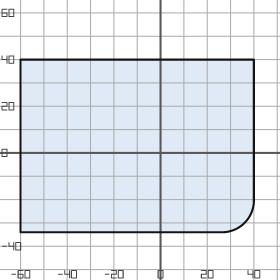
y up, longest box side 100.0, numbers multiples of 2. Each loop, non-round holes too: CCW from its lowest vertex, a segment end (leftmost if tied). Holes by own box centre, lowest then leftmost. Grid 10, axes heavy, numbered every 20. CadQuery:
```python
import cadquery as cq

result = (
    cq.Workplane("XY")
    .moveTo(-60.0, -34.0)
    .lineTo(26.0, -34.0)
    .threePointArc((36.0, -30.0), (40.0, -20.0))
    .lineTo(40.0, 40.0)
    .lineTo(-60.0, 40.0)
    .close()
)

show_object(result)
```